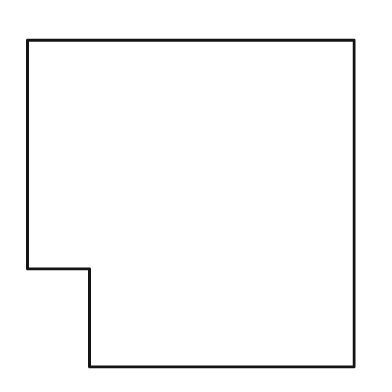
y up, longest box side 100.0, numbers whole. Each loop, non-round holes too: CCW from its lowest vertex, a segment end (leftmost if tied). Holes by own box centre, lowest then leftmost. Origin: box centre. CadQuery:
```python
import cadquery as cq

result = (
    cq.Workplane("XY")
    .moveTo(-31.0, -50.0)
    .lineTo(50.0, -50.0)
    .lineTo(50.0, 50.0)
    .lineTo(-50.0, 50.0)
    .lineTo(-50.0, -20.0)
    .lineTo(-31.0, -20.0)
    .close()
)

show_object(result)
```